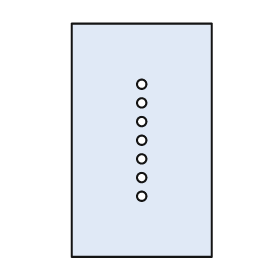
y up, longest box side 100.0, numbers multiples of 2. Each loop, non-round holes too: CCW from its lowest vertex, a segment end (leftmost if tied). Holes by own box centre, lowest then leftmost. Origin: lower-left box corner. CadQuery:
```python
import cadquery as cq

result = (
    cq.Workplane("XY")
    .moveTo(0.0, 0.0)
    .lineTo(60.0, 0.0)
    .lineTo(60.0, 100.0)
    .lineTo(0.0, 100.0)
    .close()
    .moveTo(30.0, 26.0)
    .circle(2.0)
    .moveTo(30.0, 34.0)
    .circle(2.0)
    .moveTo(30.0, 42.0)
    .circle(2.0)
    .moveTo(30.0, 50.0)
    .circle(2.0)
    .moveTo(30.0, 58.0)
    .circle(2.0)
    .moveTo(30.0, 66.0)
    .circle(2.0)
    .moveTo(30.0, 74.0)
    .circle(2.0)
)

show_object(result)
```